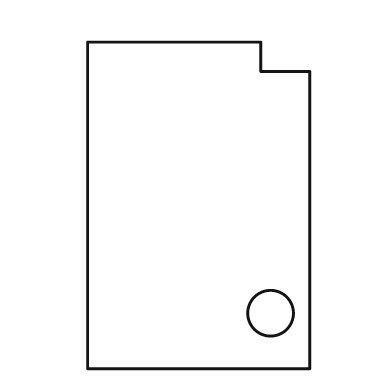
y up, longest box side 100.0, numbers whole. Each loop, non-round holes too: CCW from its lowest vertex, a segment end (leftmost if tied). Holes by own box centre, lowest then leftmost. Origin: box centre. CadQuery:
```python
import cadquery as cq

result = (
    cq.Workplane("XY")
    .moveTo(-34.0, -50.0)
    .lineTo(34.0, -50.0)
    .lineTo(34.0, 41.0)
    .lineTo(19.0, 41.0)
    .lineTo(19.0, 50.0)
    .lineTo(-34.0, 50.0)
    .close()
    .moveTo(22.0, -33.0)
    .circle(7.0)
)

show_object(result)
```